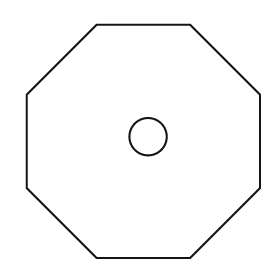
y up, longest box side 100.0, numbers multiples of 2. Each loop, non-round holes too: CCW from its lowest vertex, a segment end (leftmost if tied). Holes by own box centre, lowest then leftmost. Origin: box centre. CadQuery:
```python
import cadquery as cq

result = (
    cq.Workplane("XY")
    .moveTo(-20.0, -50.0)
    .lineTo(20.0, -50.0)
    .lineTo(50.0, -20.0)
    .lineTo(50.0, 20.0)
    .lineTo(20.0, 50.0)
    .lineTo(-20.0, 50.0)
    .lineTo(-50.0, 20.0)
    .lineTo(-50.0, -20.0)
    .close()
    .moveTo(2.0, 2.0)
    .circle(8.0)
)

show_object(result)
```